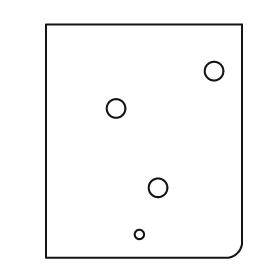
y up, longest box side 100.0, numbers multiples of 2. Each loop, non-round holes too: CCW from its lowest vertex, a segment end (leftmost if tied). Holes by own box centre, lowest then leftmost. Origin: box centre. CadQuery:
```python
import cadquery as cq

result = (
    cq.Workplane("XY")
    .moveTo(-42.0, -50.0)
    .lineTo(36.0, -50.0)
    .threePointArc((40.0, -48.0), (42.0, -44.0))
    .lineTo(42.0, 50.0)
    .lineTo(-42.0, 50.0)
    .close()
    .moveTo(-2.0, -40.0)
    .circle(2.0)
    .moveTo(6.0, -20.0)
    .circle(4.0)
    .moveTo(-12.0, 14.0)
    .circle(4.0)
    .moveTo(30.0, 30.0)
    .circle(4.0)
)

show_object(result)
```